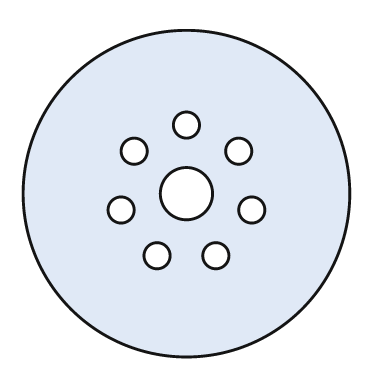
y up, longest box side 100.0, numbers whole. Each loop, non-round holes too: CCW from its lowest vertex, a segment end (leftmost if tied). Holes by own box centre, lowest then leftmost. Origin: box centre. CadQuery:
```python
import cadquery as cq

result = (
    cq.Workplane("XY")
    .moveTo(0.0, 0.0)
    .circle(50.0)
    .moveTo(-9.0, -19.0)
    .circle(4.0)
    .moveTo(9.0, -19.0)
    .circle(4.0)
    .moveTo(-20.0, -5.0)
    .circle(4.0)
    .moveTo(20.0, -5.0)
    .circle(4.0)
    .moveTo(0.0, 0.0)
    .circle(8.0)
    .moveTo(-16.0, 13.0)
    .circle(4.0)
    .moveTo(16.0, 13.0)
    .circle(4.0)
    .moveTo(0.0, 21.0)
    .circle(4.0)
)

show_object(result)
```